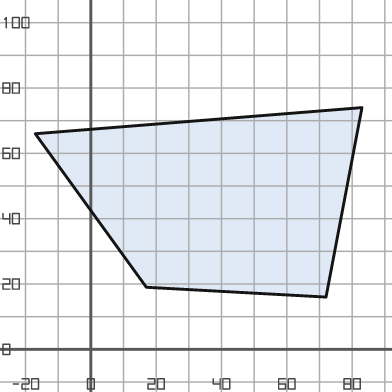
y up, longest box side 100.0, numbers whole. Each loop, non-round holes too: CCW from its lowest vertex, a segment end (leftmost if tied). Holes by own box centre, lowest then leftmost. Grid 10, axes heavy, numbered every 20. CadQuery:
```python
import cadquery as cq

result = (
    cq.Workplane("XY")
    .moveTo(72.0, 16.0)
    .lineTo(83.0, 74.0)
    .lineTo(-17.0, 66.0)
    .lineTo(17.0, 19.0)
    .close()
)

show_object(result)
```